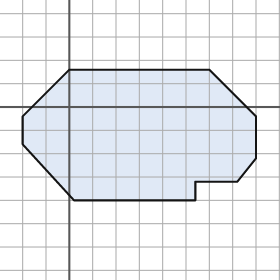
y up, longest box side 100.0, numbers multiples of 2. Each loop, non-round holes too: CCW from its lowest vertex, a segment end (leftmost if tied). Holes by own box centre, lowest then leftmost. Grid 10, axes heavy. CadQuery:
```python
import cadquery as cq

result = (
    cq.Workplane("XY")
    .moveTo(2.0, -40.0)
    .lineTo(54.0, -40.0)
    .lineTo(54.0, -32.0)
    .lineTo(72.0, -32.0)
    .lineTo(80.0, -22.0)
    .lineTo(80.0, -4.0)
    .lineTo(60.0, 16.0)
    .lineTo(0.0, 16.0)
    .lineTo(-20.0, -4.0)
    .lineTo(-20.0, -16.0)
    .close()
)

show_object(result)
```